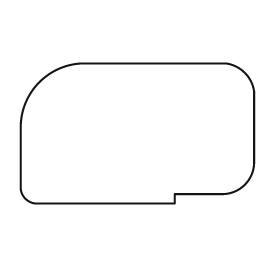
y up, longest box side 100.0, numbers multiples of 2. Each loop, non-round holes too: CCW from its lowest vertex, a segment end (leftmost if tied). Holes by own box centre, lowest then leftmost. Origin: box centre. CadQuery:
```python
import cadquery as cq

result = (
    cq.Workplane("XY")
    .moveTo(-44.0, -30.0)
    .lineTo(16.0, -30.0)
    .lineTo(16.0, -26.0)
    .lineTo(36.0, -26.0)
    .threePointArc((46.0, -22.0), (50.0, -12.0))
    .lineTo(50.0, 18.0)
    .threePointArc((46.0, 26.0), (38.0, 30.0))
    .lineTo(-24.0, 30.0)
    .threePointArc((-42.0, 22.0), (-50.0, 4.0))
    .lineTo(-50.0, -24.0)
    .threePointArc((-48.0, -28.0), (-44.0, -30.0))
    .close()
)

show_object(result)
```